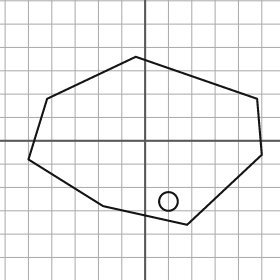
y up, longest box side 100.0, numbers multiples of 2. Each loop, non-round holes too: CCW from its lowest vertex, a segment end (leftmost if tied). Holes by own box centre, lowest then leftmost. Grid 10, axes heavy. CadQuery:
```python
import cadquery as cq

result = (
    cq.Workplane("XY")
    .moveTo(18.0, -36.0)
    .lineTo(50.0, -6.0)
    .lineTo(48.0, 18.0)
    .lineTo(-4.0, 36.0)
    .lineTo(-42.0, 18.0)
    .lineTo(-50.0, -8.0)
    .lineTo(-18.0, -28.0)
    .close()
    .moveTo(10.0, -26.0)
    .circle(4.0)
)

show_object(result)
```